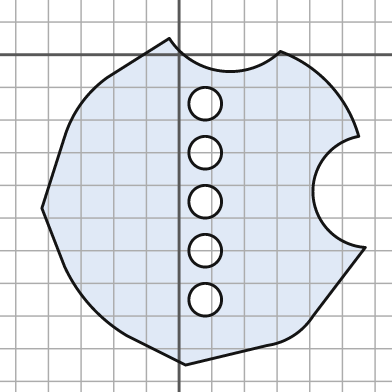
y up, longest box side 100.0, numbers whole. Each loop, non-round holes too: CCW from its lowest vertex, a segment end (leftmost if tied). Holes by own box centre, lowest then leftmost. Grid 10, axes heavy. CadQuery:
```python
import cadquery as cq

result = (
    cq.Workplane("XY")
    .moveTo(2.0, -95.0)
    .lineTo(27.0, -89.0)
    .threePointArc((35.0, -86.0), (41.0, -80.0))
    .lineTo(57.0, -59.0)
    .threePointArc((41.0, -43.0), (55.0, -25.0))
    .threePointArc((46.0, -9.0), (31.0, 1.0))
    .threePointArc((13.0, -5.0), (-3.0, 5.0))
    .lineTo(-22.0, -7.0)
    .threePointArc((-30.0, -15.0), (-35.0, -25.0))
    .lineTo(-42.0, -47.0)
    .lineTo(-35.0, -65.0)
    .threePointArc((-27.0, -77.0), (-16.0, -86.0))
    .close()
    .moveTo(8.0, -75.0)
    .circle(5.0)
    .moveTo(8.0, -60.0)
    .circle(5.0)
    .moveTo(8.0, -45.0)
    .circle(5.0)
    .moveTo(8.0, -30.0)
    .circle(5.0)
    .moveTo(8.0, -15.0)
    .circle(5.0)
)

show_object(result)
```